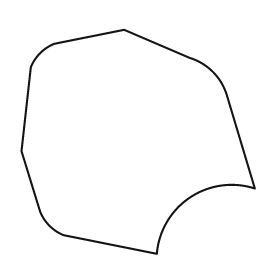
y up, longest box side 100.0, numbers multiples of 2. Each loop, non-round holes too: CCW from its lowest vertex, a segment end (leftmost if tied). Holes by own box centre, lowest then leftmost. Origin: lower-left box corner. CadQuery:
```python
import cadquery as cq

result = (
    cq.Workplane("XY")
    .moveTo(58.0, 0.0)
    .threePointArc((72.0, 24.0), (100.0, 28.0))
    .lineTo(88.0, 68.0)
    .threePointArc((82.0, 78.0), (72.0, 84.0))
    .lineTo(44.0, 96.0)
    .lineTo(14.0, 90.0)
    .threePointArc((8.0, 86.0), (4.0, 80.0))
    .lineTo(0.0, 44.0)
    .lineTo(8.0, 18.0)
    .threePointArc((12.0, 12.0), (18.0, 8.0))
    .close()
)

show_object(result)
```